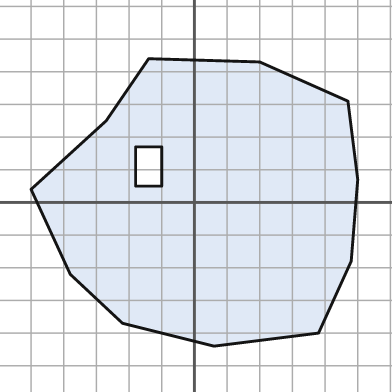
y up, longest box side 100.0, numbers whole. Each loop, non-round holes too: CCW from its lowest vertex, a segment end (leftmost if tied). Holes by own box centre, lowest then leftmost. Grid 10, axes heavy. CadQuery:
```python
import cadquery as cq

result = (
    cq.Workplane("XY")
    .moveTo(6.0, -44.0)
    .lineTo(38.0, -40.0)
    .lineTo(48.0, -18.0)
    .lineTo(50.0, 7.0)
    .lineTo(47.0, 31.0)
    .lineTo(20.0, 43.0)
    .lineTo(-14.0, 44.0)
    .lineTo(-27.0, 25.0)
    .lineTo(-50.0, 4.0)
    .lineTo(-38.0, -22.0)
    .lineTo(-22.0, -37.0)
    .close()
    .moveTo(-18.0, 5.0)
    .lineTo(-10.0, 5.0)
    .lineTo(-10.0, 17.0)
    .lineTo(-18.0, 17.0)
    .close()
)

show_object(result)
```